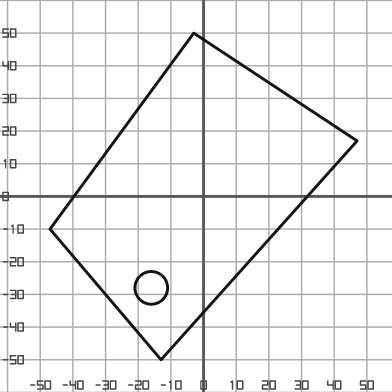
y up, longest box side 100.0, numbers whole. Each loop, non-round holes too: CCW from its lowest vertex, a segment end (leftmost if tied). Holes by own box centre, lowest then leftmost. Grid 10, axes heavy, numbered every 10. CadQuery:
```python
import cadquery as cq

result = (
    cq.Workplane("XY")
    .moveTo(-13.0, -50.0)
    .lineTo(47.0, 17.0)
    .lineTo(-3.0, 50.0)
    .lineTo(-47.0, -10.0)
    .close()
    .moveTo(-16.0, -28.0)
    .circle(5.0)
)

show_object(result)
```